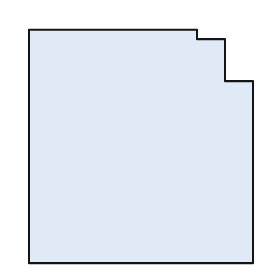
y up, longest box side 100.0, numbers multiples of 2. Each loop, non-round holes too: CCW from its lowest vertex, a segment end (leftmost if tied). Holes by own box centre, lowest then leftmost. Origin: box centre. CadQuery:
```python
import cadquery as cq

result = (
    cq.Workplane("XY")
    .moveTo(-48.0, -50.0)
    .lineTo(48.0, -50.0)
    .lineTo(48.0, 28.0)
    .lineTo(36.0, 28.0)
    .lineTo(36.0, 46.0)
    .lineTo(24.0, 46.0)
    .lineTo(24.0, 50.0)
    .lineTo(-48.0, 50.0)
    .close()
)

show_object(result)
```